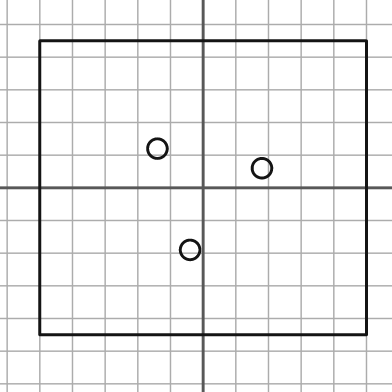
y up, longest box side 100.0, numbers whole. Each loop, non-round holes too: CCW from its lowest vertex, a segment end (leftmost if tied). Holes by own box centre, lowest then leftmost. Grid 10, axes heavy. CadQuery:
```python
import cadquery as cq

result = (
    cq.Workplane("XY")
    .moveTo(-50.0, -45.0)
    .lineTo(50.0, -45.0)
    .lineTo(50.0, 45.0)
    .lineTo(-50.0, 45.0)
    .close()
    .moveTo(-4.0, -19.0)
    .circle(3.0)
    .moveTo(18.0, 6.0)
    .circle(3.0)
    .moveTo(-14.0, 12.0)
    .circle(3.0)
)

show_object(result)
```